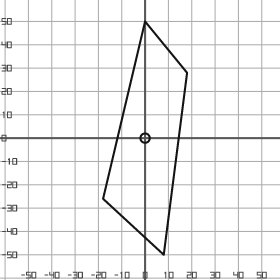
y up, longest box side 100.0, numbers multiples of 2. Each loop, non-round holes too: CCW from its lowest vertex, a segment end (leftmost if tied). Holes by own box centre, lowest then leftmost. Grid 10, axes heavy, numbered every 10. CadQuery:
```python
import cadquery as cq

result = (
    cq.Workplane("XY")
    .moveTo(8.0, -50.0)
    .lineTo(18.0, 28.0)
    .lineTo(0.0, 50.0)
    .lineTo(-18.0, -26.0)
    .close()
    .moveTo(0.0, 0.0)
    .circle(2.0)
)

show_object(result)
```